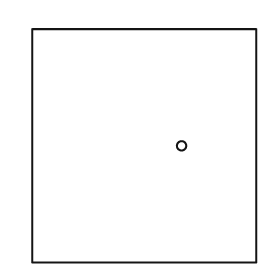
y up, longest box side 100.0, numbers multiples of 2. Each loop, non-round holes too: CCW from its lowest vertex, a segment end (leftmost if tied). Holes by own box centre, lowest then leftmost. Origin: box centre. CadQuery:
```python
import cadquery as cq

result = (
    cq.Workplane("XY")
    .moveTo(-48.0, -50.0)
    .lineTo(48.0, -50.0)
    .lineTo(48.0, 50.0)
    .lineTo(-48.0, 50.0)
    .close()
    .moveTo(16.0, 0.0)
    .circle(2.0)
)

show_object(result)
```